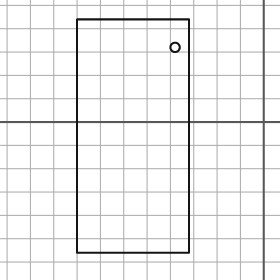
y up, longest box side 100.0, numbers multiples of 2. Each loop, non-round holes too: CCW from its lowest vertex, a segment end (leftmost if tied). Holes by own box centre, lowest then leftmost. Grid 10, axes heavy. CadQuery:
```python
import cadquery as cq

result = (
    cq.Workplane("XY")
    .moveTo(-80.0, -56.0)
    .lineTo(-32.0, -56.0)
    .lineTo(-32.0, 44.0)
    .lineTo(-80.0, 44.0)
    .close()
    .moveTo(-38.0, 32.0)
    .circle(2.0)
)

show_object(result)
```